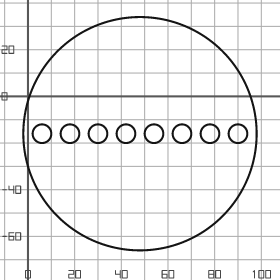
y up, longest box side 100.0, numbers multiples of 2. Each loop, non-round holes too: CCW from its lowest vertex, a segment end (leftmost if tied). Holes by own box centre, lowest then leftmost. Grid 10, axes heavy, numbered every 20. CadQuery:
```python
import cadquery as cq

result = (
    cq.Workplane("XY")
    .moveTo(48.0, -16.0)
    .circle(50.0)
    .moveTo(6.0, -16.0)
    .circle(4.0)
    .moveTo(18.0, -16.0)
    .circle(4.0)
    .moveTo(30.0, -16.0)
    .circle(4.0)
    .moveTo(42.0, -16.0)
    .circle(4.0)
    .moveTo(54.0, -16.0)
    .circle(4.0)
    .moveTo(66.0, -16.0)
    .circle(4.0)
    .moveTo(78.0, -16.0)
    .circle(4.0)
    .moveTo(90.0, -16.0)
    .circle(4.0)
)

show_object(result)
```